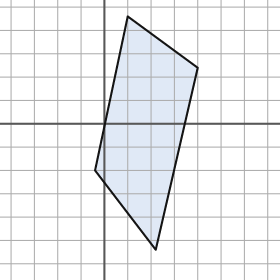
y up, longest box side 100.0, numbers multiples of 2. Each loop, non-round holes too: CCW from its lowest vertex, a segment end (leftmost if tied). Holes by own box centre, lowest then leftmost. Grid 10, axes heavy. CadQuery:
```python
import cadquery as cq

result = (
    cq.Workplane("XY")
    .moveTo(22.0, -54.0)
    .lineTo(40.0, 24.0)
    .lineTo(10.0, 46.0)
    .lineTo(-4.0, -20.0)
    .close()
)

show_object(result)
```